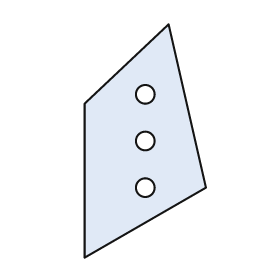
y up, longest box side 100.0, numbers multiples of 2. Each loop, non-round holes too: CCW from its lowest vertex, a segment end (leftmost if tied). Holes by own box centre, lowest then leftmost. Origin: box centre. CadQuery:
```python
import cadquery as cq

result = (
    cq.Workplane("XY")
    .moveTo(-26.0, -50.0)
    .lineTo(26.0, -20.0)
    .lineTo(10.0, 50.0)
    .lineTo(-26.0, 16.0)
    .close()
    .moveTo(0.0, -20.0)
    .circle(4.0)
    .moveTo(0.0, 0.0)
    .circle(4.0)
    .moveTo(0.0, 20.0)
    .circle(4.0)
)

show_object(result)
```